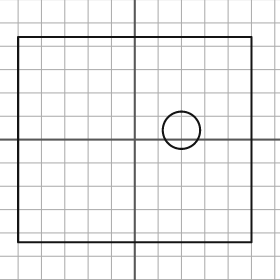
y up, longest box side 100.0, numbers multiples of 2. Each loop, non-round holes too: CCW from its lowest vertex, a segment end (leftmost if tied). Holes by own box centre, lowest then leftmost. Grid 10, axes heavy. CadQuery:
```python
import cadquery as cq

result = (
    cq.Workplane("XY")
    .moveTo(-50.0, -44.0)
    .lineTo(50.0, -44.0)
    .lineTo(50.0, 44.0)
    .lineTo(-50.0, 44.0)
    .close()
    .moveTo(20.0, 4.0)
    .circle(8.0)
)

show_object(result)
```